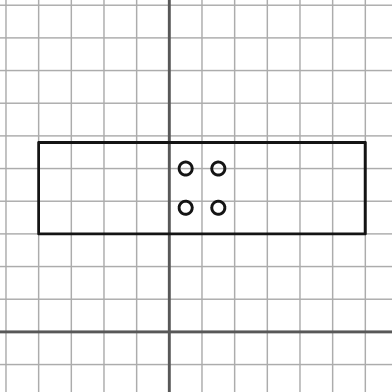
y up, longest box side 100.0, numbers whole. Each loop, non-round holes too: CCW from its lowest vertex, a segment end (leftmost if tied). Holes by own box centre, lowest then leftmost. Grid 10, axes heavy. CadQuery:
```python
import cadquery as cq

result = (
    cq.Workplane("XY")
    .moveTo(-40.0, 30.0)
    .lineTo(60.0, 30.0)
    .lineTo(60.0, 58.0)
    .lineTo(-40.0, 58.0)
    .close()
    .moveTo(5.0, 38.0)
    .circle(2.0)
    .moveTo(15.0, 38.0)
    .circle(2.0)
    .moveTo(5.0, 50.0)
    .circle(2.0)
    .moveTo(15.0, 50.0)
    .circle(2.0)
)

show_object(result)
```